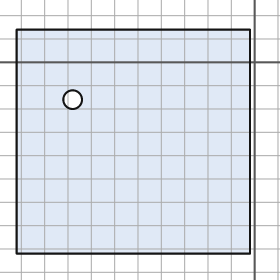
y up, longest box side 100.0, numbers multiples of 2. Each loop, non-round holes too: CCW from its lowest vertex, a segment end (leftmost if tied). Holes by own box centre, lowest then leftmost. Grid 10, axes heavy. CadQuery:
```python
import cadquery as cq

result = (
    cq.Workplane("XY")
    .moveTo(-102.0, -82.0)
    .lineTo(-2.0, -82.0)
    .lineTo(-2.0, 14.0)
    .lineTo(-102.0, 14.0)
    .close()
    .moveTo(-78.0, -16.0)
    .circle(4.0)
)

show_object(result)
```